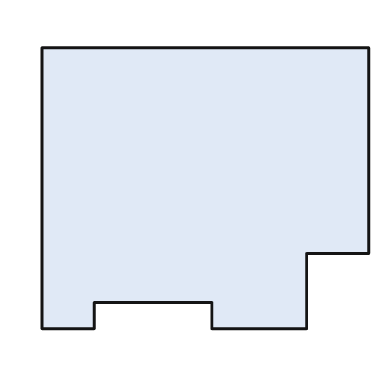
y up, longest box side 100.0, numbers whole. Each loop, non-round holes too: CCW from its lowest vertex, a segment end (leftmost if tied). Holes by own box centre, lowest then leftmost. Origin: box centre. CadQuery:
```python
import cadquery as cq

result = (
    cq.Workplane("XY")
    .moveTo(-50.0, -43.0)
    .lineTo(-34.0, -43.0)
    .lineTo(-34.0, -35.0)
    .lineTo(2.0, -35.0)
    .lineTo(2.0, -43.0)
    .lineTo(31.0, -43.0)
    .lineTo(31.0, -20.0)
    .lineTo(50.0, -20.0)
    .lineTo(50.0, 43.0)
    .lineTo(-50.0, 43.0)
    .close()
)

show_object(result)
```